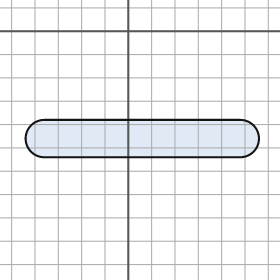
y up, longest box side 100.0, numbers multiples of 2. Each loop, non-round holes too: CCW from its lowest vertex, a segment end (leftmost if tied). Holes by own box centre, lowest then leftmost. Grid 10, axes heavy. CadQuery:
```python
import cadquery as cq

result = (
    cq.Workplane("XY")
    .moveTo(-36.0, -54.0)
    .lineTo(48.0, -54.0)
    .threePointArc((56.0, -46.0), (48.0, -38.0))
    .lineTo(-36.0, -38.0)
    .threePointArc((-44.0, -46.0), (-36.0, -54.0))
    .close()
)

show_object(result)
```